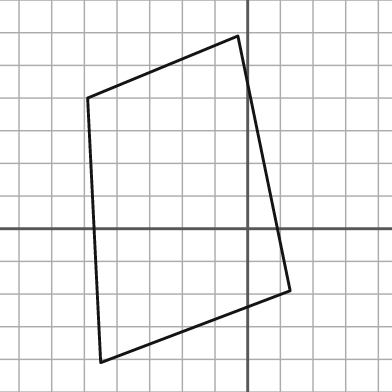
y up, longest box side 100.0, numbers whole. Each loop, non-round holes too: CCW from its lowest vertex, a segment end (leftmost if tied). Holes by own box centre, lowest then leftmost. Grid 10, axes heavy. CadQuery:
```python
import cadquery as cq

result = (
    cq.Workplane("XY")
    .moveTo(-45.0, -41.0)
    .lineTo(13.0, -19.0)
    .lineTo(-3.0, 59.0)
    .lineTo(-49.0, 40.0)
    .close()
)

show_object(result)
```